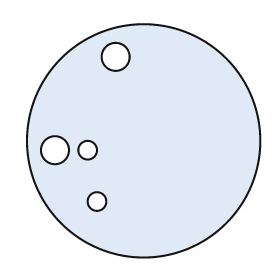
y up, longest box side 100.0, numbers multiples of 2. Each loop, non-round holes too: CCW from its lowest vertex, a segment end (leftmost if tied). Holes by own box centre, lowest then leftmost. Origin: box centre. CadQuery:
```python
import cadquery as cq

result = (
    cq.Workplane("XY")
    .moveTo(0.0, 0.0)
    .circle(50.0)
    .moveTo(-20.0, -26.0)
    .circle(4.0)
    .moveTo(-38.0, -4.0)
    .circle(6.0)
    .moveTo(-24.0, -4.0)
    .circle(4.0)
    .moveTo(-12.0, 36.0)
    .circle(6.0)
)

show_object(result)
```